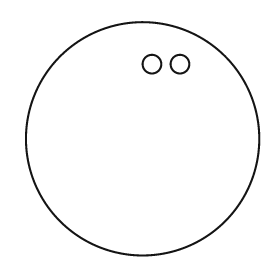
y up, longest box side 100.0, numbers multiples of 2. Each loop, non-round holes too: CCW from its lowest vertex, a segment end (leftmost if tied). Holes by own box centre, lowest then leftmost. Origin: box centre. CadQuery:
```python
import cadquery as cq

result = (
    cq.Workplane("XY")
    .moveTo(0.0, 0.0)
    .circle(50.0)
    .moveTo(4.0, 32.0)
    .circle(4.0)
    .moveTo(16.0, 32.0)
    .circle(4.0)
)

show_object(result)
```